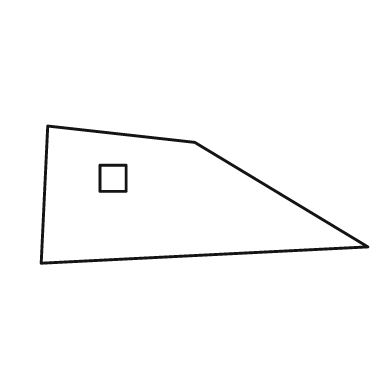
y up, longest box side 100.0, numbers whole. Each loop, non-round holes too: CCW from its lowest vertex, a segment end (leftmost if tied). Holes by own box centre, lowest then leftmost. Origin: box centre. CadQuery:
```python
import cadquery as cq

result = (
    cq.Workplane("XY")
    .moveTo(-50.0, -21.0)
    .lineTo(50.0, -16.0)
    .lineTo(-3.0, 16.0)
    .lineTo(-48.0, 21.0)
    .close()
    .moveTo(-32.0, 1.0)
    .lineTo(-24.0, 1.0)
    .lineTo(-24.0, 9.0)
    .lineTo(-32.0, 9.0)
    .close()
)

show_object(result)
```